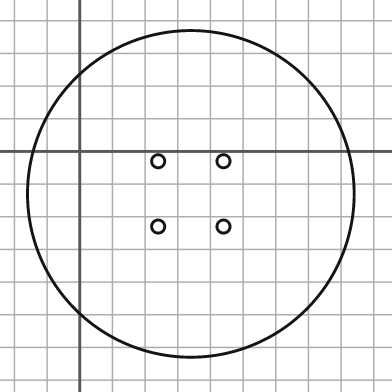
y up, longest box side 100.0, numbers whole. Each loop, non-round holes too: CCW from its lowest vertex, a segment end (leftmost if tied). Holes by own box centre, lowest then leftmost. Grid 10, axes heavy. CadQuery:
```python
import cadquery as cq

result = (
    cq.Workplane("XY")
    .moveTo(34.0, -13.0)
    .circle(50.0)
    .moveTo(24.0, -23.0)
    .circle(2.0)
    .moveTo(44.0, -23.0)
    .circle(2.0)
    .moveTo(24.0, -3.0)
    .circle(2.0)
    .moveTo(44.0, -3.0)
    .circle(2.0)
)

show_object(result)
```